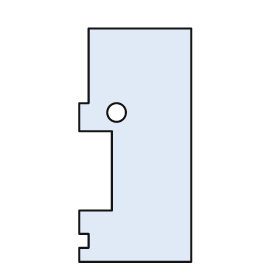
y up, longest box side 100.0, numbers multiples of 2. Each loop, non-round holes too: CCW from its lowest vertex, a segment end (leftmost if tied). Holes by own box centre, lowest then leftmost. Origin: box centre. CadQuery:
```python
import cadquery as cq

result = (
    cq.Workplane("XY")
    .moveTo(-24.0, -50.0)
    .lineTo(24.0, -50.0)
    .lineTo(24.0, 50.0)
    .lineTo(-20.0, 50.0)
    .lineTo(-20.0, 18.0)
    .lineTo(-24.0, 18.0)
    .lineTo(-24.0, 6.0)
    .lineTo(-10.0, 6.0)
    .lineTo(-10.0, -28.0)
    .lineTo(-24.0, -28.0)
    .lineTo(-24.0, -38.0)
    .lineTo(-20.0, -38.0)
    .lineTo(-20.0, -44.0)
    .lineTo(-24.0, -44.0)
    .close()
    .moveTo(-8.0, 14.0)
    .circle(4.0)
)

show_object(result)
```